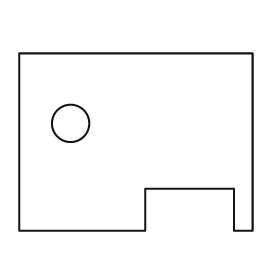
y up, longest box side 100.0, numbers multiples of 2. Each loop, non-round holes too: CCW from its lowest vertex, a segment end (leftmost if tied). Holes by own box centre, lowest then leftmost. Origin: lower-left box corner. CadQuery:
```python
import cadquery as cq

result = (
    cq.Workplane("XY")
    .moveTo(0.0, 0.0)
    .lineTo(54.0, 0.0)
    .lineTo(54.0, 18.0)
    .lineTo(92.0, 18.0)
    .lineTo(92.0, 0.0)
    .lineTo(100.0, 0.0)
    .lineTo(100.0, 76.0)
    .lineTo(0.0, 76.0)
    .close()
    .moveTo(22.0, 46.0)
    .circle(8.0)
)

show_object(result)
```